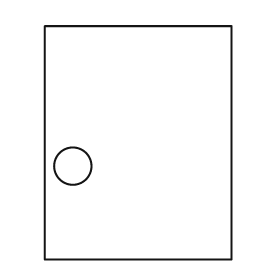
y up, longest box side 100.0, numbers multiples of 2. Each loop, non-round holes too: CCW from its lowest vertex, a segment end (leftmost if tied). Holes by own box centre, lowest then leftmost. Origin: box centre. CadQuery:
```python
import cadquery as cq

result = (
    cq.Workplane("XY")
    .moveTo(-40.0, -50.0)
    .lineTo(40.0, -50.0)
    .lineTo(40.0, 50.0)
    .lineTo(-40.0, 50.0)
    .close()
    .moveTo(-28.0, -10.0)
    .circle(8.0)
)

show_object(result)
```